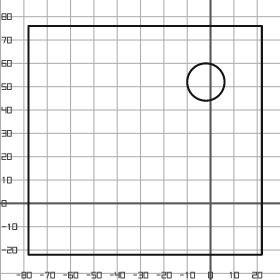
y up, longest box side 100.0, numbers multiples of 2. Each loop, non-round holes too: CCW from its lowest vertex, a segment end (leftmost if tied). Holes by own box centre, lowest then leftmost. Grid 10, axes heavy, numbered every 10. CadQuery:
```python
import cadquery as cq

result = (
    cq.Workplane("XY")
    .moveTo(-78.0, -22.0)
    .lineTo(22.0, -22.0)
    .lineTo(22.0, 76.0)
    .lineTo(-78.0, 76.0)
    .close()
    .moveTo(-2.0, 52.0)
    .circle(8.0)
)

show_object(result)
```